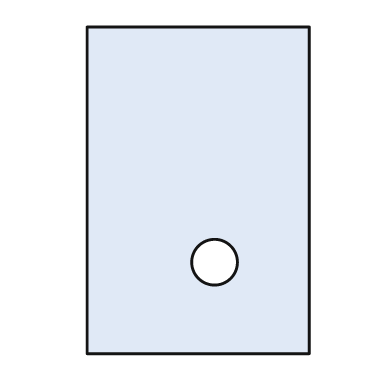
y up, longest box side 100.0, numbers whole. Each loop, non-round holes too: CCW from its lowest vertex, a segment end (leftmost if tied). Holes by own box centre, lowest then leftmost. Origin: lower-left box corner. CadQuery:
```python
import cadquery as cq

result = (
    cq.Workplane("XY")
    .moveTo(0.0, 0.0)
    .lineTo(68.0, 0.0)
    .lineTo(68.0, 100.0)
    .lineTo(0.0, 100.0)
    .close()
    .moveTo(39.0, 28.0)
    .circle(7.0)
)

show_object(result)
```